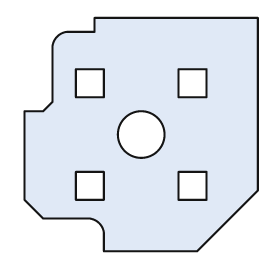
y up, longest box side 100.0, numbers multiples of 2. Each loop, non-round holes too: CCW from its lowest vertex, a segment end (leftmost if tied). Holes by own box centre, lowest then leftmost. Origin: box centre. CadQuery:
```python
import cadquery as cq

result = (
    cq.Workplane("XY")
    .moveTo(-16.0, -50.0)
    .lineTo(24.0, -50.0)
    .lineTo(50.0, -24.0)
    .lineTo(50.0, 50.0)
    .lineTo(-20.0, 50.0)
    .lineTo(-20.0, 44.0)
    .lineTo(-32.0, 44.0)
    .threePointArc((-36.0, 42.0), (-38.0, 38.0))
    .lineTo(-38.0, 14.0)
    .lineTo(-42.0, 10.0)
    .lineTo(-50.0, 10.0)
    .lineTo(-50.0, -28.0)
    .lineTo(-42.0, -36.0)
    .lineTo(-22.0, -36.0)
    .threePointArc((-18.0, -38.0), (-16.0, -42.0))
    .close()
    .moveTo(-28.0, -28.0)
    .lineTo(-16.0, -28.0)
    .lineTo(-16.0, -16.0)
    .lineTo(-28.0, -16.0)
    .close()
    .moveTo(16.0, -28.0)
    .lineTo(28.0, -28.0)
    .lineTo(28.0, -16.0)
    .lineTo(16.0, -16.0)
    .close()
    .moveTo(0.0, 0.0)
    .circle(10.0)
    .moveTo(-28.0, 16.0)
    .lineTo(-16.0, 16.0)
    .lineTo(-16.0, 28.0)
    .lineTo(-28.0, 28.0)
    .close()
    .moveTo(16.0, 16.0)
    .lineTo(28.0, 16.0)
    .lineTo(28.0, 28.0)
    .lineTo(16.0, 28.0)
    .close()
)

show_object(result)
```